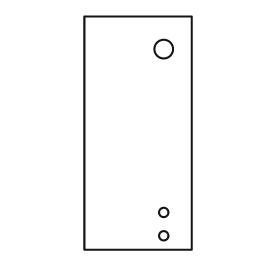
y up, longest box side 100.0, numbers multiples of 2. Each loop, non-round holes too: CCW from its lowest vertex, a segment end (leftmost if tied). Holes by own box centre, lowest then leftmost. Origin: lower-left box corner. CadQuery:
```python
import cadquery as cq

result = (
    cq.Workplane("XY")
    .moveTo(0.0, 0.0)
    .lineTo(46.0, 0.0)
    .lineTo(46.0, 100.0)
    .lineTo(0.0, 100.0)
    .close()
    .moveTo(34.0, 6.0)
    .circle(2.0)
    .moveTo(34.0, 16.0)
    .circle(2.0)
    .moveTo(34.0, 86.0)
    .circle(4.0)
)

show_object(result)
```